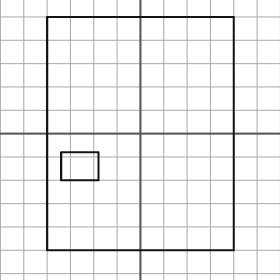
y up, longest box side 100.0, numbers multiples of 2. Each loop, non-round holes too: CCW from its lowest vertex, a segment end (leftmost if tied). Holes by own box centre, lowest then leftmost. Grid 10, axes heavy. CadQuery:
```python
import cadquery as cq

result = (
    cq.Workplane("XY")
    .moveTo(-40.0, -50.0)
    .lineTo(40.0, -50.0)
    .lineTo(40.0, 50.0)
    .lineTo(-40.0, 50.0)
    .close()
    .moveTo(-34.0, -20.0)
    .lineTo(-18.0, -20.0)
    .lineTo(-18.0, -8.0)
    .lineTo(-34.0, -8.0)
    .close()
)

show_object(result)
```